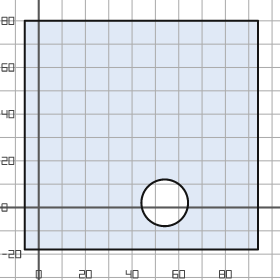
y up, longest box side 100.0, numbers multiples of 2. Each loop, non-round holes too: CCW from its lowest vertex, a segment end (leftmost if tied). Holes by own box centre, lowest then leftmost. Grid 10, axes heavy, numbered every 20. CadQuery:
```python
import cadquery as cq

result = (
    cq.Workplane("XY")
    .moveTo(-6.0, -18.0)
    .lineTo(94.0, -18.0)
    .lineTo(94.0, 80.0)
    .lineTo(-6.0, 80.0)
    .close()
    .moveTo(54.0, 2.0)
    .circle(10.0)
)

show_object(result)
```